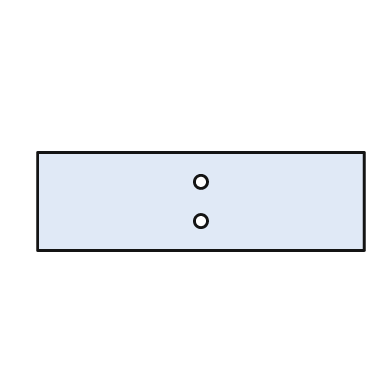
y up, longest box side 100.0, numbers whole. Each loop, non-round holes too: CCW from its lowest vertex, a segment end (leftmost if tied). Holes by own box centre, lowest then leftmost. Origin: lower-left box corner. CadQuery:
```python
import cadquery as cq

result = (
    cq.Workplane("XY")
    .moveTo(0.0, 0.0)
    .lineTo(100.0, 0.0)
    .lineTo(100.0, 30.0)
    .lineTo(0.0, 30.0)
    .close()
    .moveTo(50.0, 9.0)
    .circle(2.0)
    .moveTo(50.0, 21.0)
    .circle(2.0)
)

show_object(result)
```